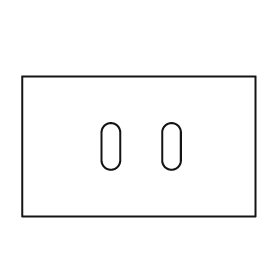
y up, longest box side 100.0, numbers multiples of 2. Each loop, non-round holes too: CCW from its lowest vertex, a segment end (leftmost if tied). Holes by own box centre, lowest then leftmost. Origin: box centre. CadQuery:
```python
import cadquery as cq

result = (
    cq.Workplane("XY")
    .moveTo(-50.0, -30.0)
    .lineTo(50.0, -30.0)
    .lineTo(50.0, 30.0)
    .lineTo(-50.0, 30.0)
    .close()
    .moveTo(-16.0, -6.0)
    .threePointArc((-12.0, -10.0), (-8.0, -6.0))
    .lineTo(-8.0, 6.0)
    .threePointArc((-12.0, 10.0), (-16.0, 6.0))
    .close()
    .moveTo(10.0, -6.0)
    .threePointArc((14.0, -10.0), (18.0, -6.0))
    .lineTo(18.0, 6.0)
    .threePointArc((14.0, 10.0), (10.0, 6.0))
    .close()
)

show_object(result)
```